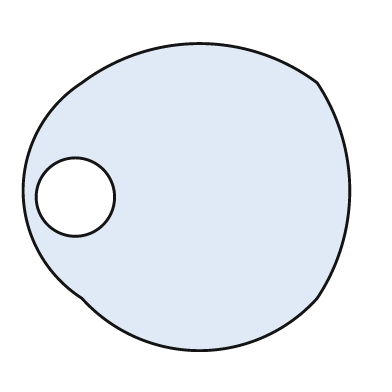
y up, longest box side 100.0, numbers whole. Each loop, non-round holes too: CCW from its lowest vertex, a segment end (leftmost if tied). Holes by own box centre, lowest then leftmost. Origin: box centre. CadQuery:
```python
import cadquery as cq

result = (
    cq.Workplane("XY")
    .moveTo(-32.0, -31.0)
    .threePointArc((4.0, -47.0), (40.0, -31.0))
    .threePointArc((50.0, 2.0), (40.0, 35.0))
    .threePointArc((4.0, 47.0), (-32.0, 35.0))
    .threePointArc((-50.0, 2.0), (-32.0, -31.0))
    .close()
    .moveTo(-34.0, 0.0)
    .circle(12.0)
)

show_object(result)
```